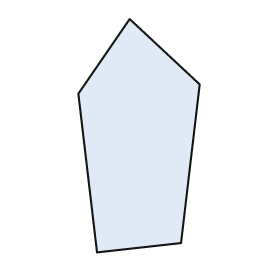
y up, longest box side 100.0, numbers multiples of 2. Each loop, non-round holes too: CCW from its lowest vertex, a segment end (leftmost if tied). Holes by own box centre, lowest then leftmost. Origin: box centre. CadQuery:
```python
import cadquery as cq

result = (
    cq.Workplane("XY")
    .moveTo(-18.0, -50.0)
    .lineTo(18.0, -46.0)
    .lineTo(26.0, 22.0)
    .lineTo(-4.0, 50.0)
    .lineTo(-26.0, 18.0)
    .close()
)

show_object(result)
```